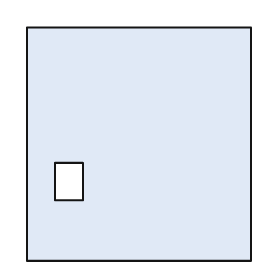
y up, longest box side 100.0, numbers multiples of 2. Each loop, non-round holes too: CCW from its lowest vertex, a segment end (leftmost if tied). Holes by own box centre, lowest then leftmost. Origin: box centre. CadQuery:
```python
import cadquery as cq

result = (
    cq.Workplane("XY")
    .moveTo(-48.0, -50.0)
    .lineTo(48.0, -50.0)
    .lineTo(48.0, 50.0)
    .lineTo(-48.0, 50.0)
    .close()
    .moveTo(-36.0, -24.0)
    .lineTo(-24.0, -24.0)
    .lineTo(-24.0, -8.0)
    .lineTo(-36.0, -8.0)
    .close()
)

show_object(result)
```